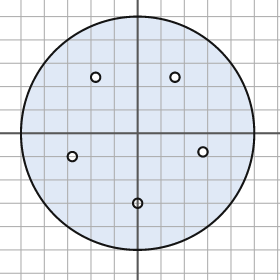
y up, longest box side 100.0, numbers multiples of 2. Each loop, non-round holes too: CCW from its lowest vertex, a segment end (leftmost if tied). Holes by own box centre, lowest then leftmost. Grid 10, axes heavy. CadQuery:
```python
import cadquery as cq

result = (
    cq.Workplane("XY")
    .moveTo(0.0, 0.0)
    .circle(50.0)
    .moveTo(0.0, -30.0)
    .circle(2.0)
    .moveTo(-28.0, -10.0)
    .circle(2.0)
    .moveTo(28.0, -8.0)
    .circle(2.0)
    .moveTo(-18.0, 24.0)
    .circle(2.0)
    .moveTo(16.0, 24.0)
    .circle(2.0)
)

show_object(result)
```